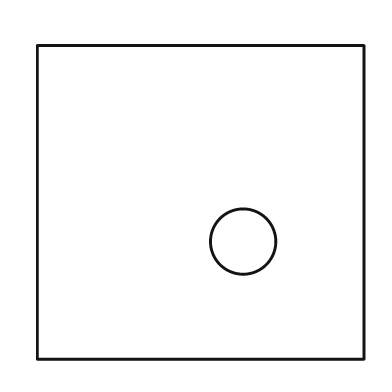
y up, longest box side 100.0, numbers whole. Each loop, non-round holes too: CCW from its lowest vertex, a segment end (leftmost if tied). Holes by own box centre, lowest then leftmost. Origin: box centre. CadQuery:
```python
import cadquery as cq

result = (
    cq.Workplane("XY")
    .moveTo(-50.0, -48.0)
    .lineTo(50.0, -48.0)
    .lineTo(50.0, 48.0)
    .lineTo(-50.0, 48.0)
    .close()
    .moveTo(13.0, -12.0)
    .circle(10.0)
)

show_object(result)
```